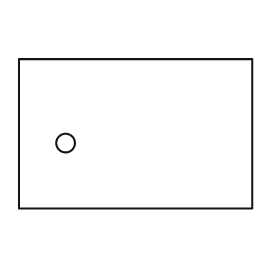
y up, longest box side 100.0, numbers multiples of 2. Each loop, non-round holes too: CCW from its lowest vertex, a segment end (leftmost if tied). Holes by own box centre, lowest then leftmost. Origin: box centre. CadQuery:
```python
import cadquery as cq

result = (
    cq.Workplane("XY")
    .moveTo(-50.0, -32.0)
    .lineTo(50.0, -32.0)
    .lineTo(50.0, 32.0)
    .lineTo(-50.0, 32.0)
    .close()
    .moveTo(-30.0, -4.0)
    .circle(4.0)
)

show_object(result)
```